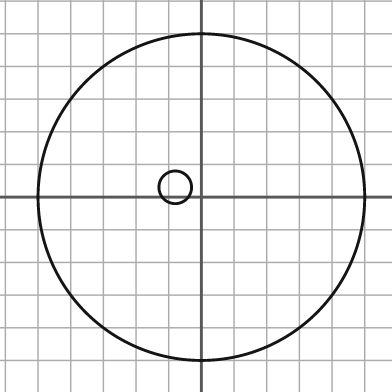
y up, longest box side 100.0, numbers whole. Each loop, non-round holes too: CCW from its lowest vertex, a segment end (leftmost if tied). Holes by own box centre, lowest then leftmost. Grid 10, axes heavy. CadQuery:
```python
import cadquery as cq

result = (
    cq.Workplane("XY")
    .moveTo(0.0, 0.0)
    .circle(50.0)
    .moveTo(-8.0, 3.0)
    .circle(5.0)
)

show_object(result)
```